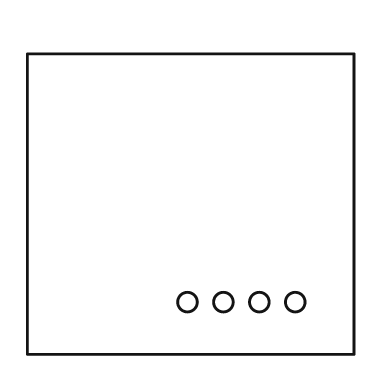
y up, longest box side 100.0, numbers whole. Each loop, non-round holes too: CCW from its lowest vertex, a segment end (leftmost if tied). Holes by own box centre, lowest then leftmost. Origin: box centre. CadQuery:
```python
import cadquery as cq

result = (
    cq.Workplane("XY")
    .moveTo(-50.0, -46.0)
    .lineTo(50.0, -46.0)
    .lineTo(50.0, 46.0)
    .lineTo(-50.0, 46.0)
    .close()
    .moveTo(-1.0, -30.0)
    .circle(3.0)
    .moveTo(10.0, -30.0)
    .circle(3.0)
    .moveTo(21.0, -30.0)
    .circle(3.0)
    .moveTo(32.0, -30.0)
    .circle(3.0)
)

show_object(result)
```